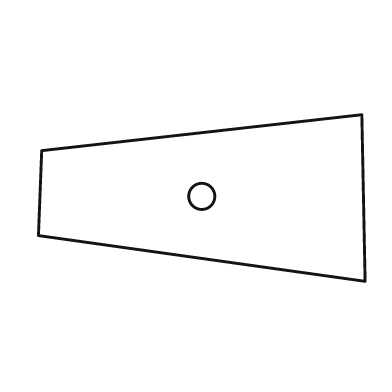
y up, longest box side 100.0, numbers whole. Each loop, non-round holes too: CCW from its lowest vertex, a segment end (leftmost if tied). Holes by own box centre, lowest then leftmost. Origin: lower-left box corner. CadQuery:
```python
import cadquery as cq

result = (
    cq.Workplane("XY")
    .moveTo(100.0, 0.0)
    .lineTo(99.0, 51.0)
    .lineTo(1.0, 40.0)
    .lineTo(0.0, 14.0)
    .close()
    .moveTo(50.0, 26.0)
    .circle(4.0)
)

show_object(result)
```